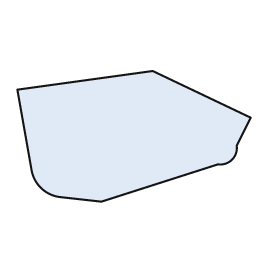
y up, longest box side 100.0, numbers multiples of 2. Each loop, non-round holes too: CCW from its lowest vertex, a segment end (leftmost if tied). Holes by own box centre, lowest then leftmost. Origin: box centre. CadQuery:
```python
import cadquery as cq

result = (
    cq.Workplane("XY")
    .moveTo(-14.0, -28.0)
    .lineTo(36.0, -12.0)
    .threePointArc((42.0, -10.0), (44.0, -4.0))
    .lineTo(50.0, 8.0)
    .lineTo(8.0, 28.0)
    .lineTo(-50.0, 20.0)
    .lineTo(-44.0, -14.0)
    .threePointArc((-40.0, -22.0), (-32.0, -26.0))
    .close()
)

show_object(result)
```